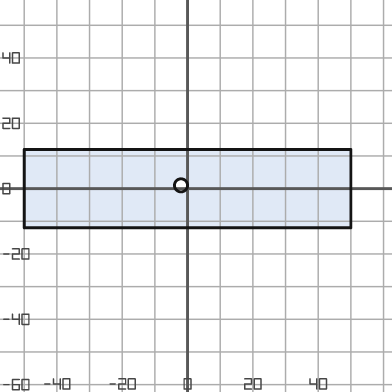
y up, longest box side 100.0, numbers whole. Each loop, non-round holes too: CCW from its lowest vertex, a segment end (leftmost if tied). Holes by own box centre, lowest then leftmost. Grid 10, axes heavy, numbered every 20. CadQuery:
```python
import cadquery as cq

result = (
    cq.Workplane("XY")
    .moveTo(-50.0, -12.0)
    .lineTo(50.0, -12.0)
    .lineTo(50.0, 12.0)
    .lineTo(-50.0, 12.0)
    .close()
    .moveTo(-2.0, 1.0)
    .circle(2.0)
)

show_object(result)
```